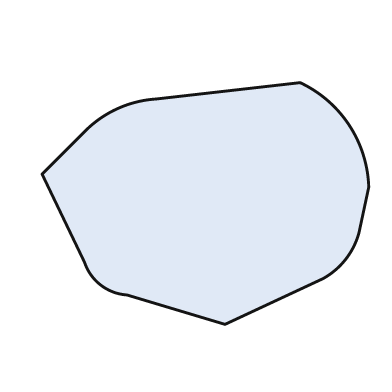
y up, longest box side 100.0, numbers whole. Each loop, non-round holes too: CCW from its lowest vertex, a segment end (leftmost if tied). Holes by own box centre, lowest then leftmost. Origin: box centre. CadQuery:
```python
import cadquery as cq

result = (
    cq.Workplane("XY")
    .moveTo(6.0, -37.0)
    .lineTo(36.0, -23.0)
    .threePointArc((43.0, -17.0), (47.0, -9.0))
    .lineTo(50.0, 5.0)
    .threePointArc((44.0, 24.0), (29.0, 37.0))
    .lineTo(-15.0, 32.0)
    .threePointArc((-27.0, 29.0), (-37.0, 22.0))
    .lineTo(-50.0, 9.0)
    .lineTo(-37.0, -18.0)
    .threePointArc((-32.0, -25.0), (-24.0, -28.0))
    .close()
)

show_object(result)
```